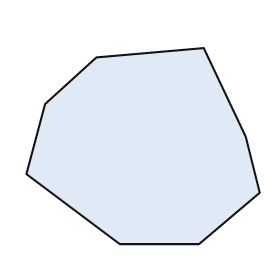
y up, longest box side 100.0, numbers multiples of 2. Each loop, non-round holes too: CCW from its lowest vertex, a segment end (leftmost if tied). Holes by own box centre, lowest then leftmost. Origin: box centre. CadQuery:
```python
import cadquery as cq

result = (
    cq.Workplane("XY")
    .moveTo(-10.0, -42.0)
    .lineTo(24.0, -42.0)
    .lineTo(50.0, -20.0)
    .lineTo(44.0, 4.0)
    .lineTo(26.0, 42.0)
    .lineTo(-20.0, 38.0)
    .lineTo(-42.0, 18.0)
    .lineTo(-50.0, -12.0)
    .close()
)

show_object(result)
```